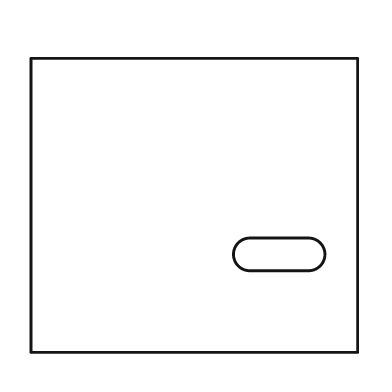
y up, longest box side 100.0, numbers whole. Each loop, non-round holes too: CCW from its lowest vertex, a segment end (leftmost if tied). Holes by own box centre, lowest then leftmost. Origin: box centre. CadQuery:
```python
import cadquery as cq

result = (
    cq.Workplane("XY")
    .moveTo(-50.0, -45.0)
    .lineTo(50.0, -45.0)
    .lineTo(50.0, 45.0)
    .lineTo(-50.0, 45.0)
    .close()
    .moveTo(17.0, -20.0)
    .lineTo(35.0, -20.0)
    .threePointArc((40.0, -15.0), (35.0, -10.0))
    .lineTo(17.0, -10.0)
    .threePointArc((12.0, -15.0), (17.0, -20.0))
    .close()
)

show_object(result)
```